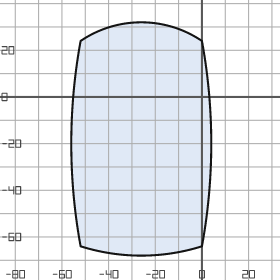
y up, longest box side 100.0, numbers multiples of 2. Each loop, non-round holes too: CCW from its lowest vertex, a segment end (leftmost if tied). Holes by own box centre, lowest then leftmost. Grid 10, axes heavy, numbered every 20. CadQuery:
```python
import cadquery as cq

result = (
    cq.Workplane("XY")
    .moveTo(-52.0, -64.0)
    .threePointArc((-26.0, -68.0), (0.0, -64.0))
    .threePointArc((4.0, -20.0), (0.0, 24.0))
    .threePointArc((-26.0, 32.0), (-52.0, 24.0))
    .threePointArc((-56.0, -20.0), (-52.0, -64.0))
    .close()
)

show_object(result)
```